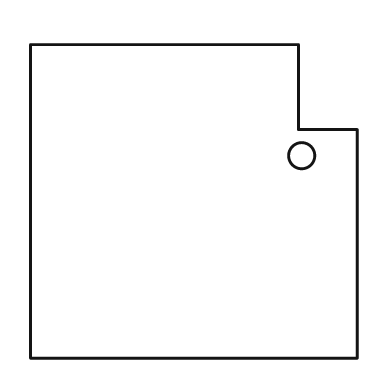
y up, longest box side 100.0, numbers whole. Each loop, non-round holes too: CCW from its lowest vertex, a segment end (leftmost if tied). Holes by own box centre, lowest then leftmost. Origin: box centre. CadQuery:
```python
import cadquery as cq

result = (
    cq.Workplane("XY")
    .moveTo(-50.0, -48.0)
    .lineTo(50.0, -48.0)
    .lineTo(50.0, 22.0)
    .lineTo(32.0, 22.0)
    .lineTo(32.0, 48.0)
    .lineTo(-50.0, 48.0)
    .close()
    .moveTo(33.0, 14.0)
    .circle(4.0)
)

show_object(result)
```